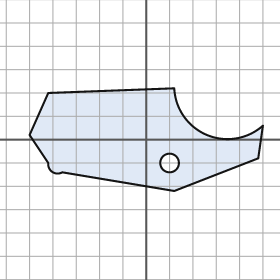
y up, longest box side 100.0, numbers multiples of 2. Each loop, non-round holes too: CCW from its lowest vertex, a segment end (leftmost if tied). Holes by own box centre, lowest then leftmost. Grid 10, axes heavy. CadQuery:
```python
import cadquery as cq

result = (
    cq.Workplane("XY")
    .moveTo(12.0, -22.0)
    .lineTo(48.0, -8.0)
    .lineTo(50.0, 6.0)
    .threePointArc((26.0, 2.0), (12.0, 22.0))
    .lineTo(-42.0, 20.0)
    .lineTo(-50.0, 2.0)
    .lineTo(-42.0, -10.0)
    .threePointArc((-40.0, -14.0), (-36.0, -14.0))
    .close()
    .moveTo(10.0, -10.0)
    .circle(4.0)
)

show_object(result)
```